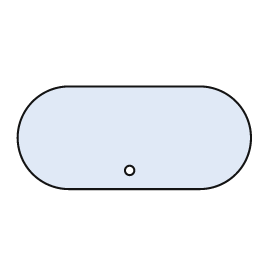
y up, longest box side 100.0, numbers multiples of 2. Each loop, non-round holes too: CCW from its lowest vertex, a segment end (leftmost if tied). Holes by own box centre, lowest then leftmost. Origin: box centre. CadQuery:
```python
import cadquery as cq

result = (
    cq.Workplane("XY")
    .moveTo(-28.0, -22.0)
    .lineTo(28.0, -22.0)
    .threePointArc((50.0, 0.0), (28.0, 22.0))
    .lineTo(-28.0, 22.0)
    .threePointArc((-50.0, 0.0), (-28.0, -22.0))
    .close()
    .moveTo(-2.0, -14.0)
    .circle(2.0)
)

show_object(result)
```